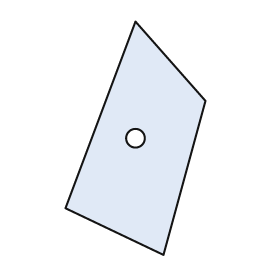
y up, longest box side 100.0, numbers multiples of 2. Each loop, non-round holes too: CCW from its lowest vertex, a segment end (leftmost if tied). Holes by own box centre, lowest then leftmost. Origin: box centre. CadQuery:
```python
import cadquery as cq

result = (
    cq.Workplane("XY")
    .moveTo(12.0, -50.0)
    .lineTo(30.0, 16.0)
    .lineTo(0.0, 50.0)
    .lineTo(-30.0, -30.0)
    .close()
    .moveTo(0.0, 0.0)
    .circle(4.0)
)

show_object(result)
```